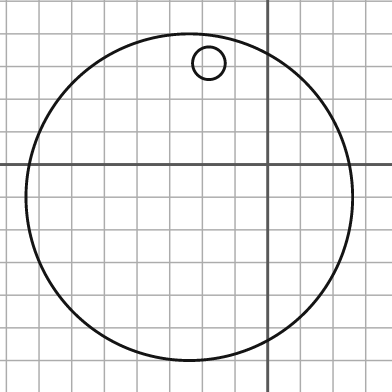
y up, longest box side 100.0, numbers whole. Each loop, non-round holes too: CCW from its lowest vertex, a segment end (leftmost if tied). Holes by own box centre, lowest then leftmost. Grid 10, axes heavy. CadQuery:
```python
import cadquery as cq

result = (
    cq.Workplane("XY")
    .moveTo(-24.0, -10.0)
    .circle(50.0)
    .moveTo(-18.0, 31.0)
    .circle(5.0)
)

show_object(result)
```